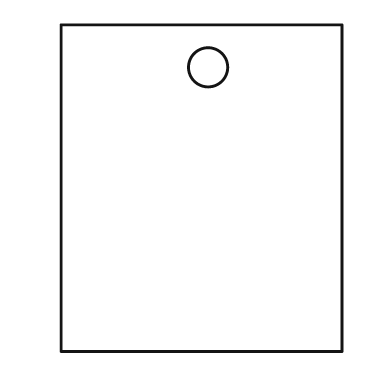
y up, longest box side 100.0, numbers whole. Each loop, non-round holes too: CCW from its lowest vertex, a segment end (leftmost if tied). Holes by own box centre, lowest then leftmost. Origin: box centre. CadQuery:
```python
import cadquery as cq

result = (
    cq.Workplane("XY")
    .moveTo(-43.0, -50.0)
    .lineTo(43.0, -50.0)
    .lineTo(43.0, 50.0)
    .lineTo(-43.0, 50.0)
    .close()
    .moveTo(2.0, 37.0)
    .circle(6.0)
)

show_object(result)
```